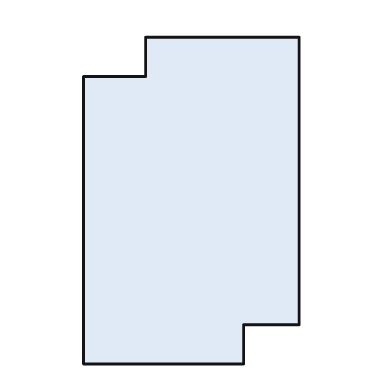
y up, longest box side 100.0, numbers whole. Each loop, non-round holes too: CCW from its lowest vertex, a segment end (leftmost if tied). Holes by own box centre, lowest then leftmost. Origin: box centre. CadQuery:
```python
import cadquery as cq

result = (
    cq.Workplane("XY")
    .moveTo(-33.0, -50.0)
    .lineTo(16.0, -50.0)
    .lineTo(16.0, -38.0)
    .lineTo(33.0, -38.0)
    .lineTo(33.0, 50.0)
    .lineTo(-14.0, 50.0)
    .lineTo(-14.0, 38.0)
    .lineTo(-33.0, 38.0)
    .close()
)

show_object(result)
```